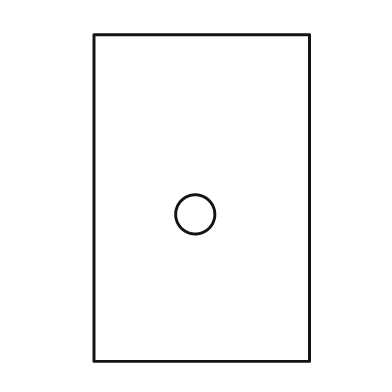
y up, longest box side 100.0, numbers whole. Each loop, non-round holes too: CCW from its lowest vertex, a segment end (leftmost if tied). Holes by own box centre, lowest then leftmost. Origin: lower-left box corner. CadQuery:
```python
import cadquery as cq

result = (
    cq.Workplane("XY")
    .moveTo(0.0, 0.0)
    .lineTo(66.0, 0.0)
    .lineTo(66.0, 100.0)
    .lineTo(0.0, 100.0)
    .close()
    .moveTo(31.0, 45.0)
    .circle(6.0)
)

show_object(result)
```